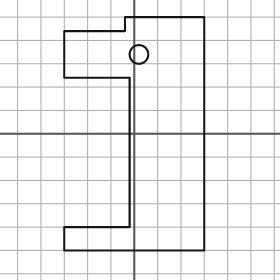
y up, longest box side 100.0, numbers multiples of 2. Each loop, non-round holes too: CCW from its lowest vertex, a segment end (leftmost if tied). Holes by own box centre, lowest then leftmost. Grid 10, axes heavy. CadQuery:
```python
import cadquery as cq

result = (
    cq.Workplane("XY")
    .moveTo(-30.0, -50.0)
    .lineTo(30.0, -50.0)
    .lineTo(30.0, 50.0)
    .lineTo(-4.0, 50.0)
    .lineTo(-4.0, 44.0)
    .lineTo(-30.0, 44.0)
    .lineTo(-30.0, 24.0)
    .lineTo(-2.0, 24.0)
    .lineTo(-2.0, -40.0)
    .lineTo(-30.0, -40.0)
    .close()
    .moveTo(2.0, 34.0)
    .circle(4.0)
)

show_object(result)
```